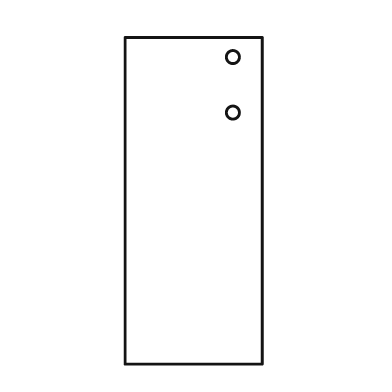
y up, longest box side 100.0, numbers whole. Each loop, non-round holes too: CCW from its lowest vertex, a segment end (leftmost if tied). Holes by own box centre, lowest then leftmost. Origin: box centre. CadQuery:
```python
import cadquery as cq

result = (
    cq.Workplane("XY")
    .moveTo(-21.0, -50.0)
    .lineTo(21.0, -50.0)
    .lineTo(21.0, 50.0)
    .lineTo(-21.0, 50.0)
    .close()
    .moveTo(12.0, 27.0)
    .circle(2.0)
    .moveTo(12.0, 44.0)
    .circle(2.0)
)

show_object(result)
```